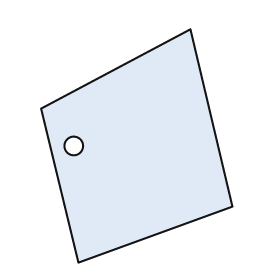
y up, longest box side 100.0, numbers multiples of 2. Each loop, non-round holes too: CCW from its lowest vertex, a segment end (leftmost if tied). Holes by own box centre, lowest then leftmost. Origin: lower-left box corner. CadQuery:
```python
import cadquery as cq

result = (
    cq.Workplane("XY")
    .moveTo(16.0, 0.0)
    .lineTo(82.0, 24.0)
    .lineTo(64.0, 100.0)
    .lineTo(0.0, 66.0)
    .close()
    .moveTo(14.0, 50.0)
    .circle(4.0)
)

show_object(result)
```